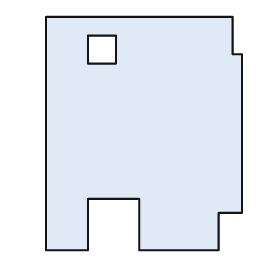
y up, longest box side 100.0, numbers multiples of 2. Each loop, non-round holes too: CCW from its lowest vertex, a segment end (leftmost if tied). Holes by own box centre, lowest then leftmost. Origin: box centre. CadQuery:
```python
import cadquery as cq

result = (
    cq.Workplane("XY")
    .moveTo(-42.0, -50.0)
    .lineTo(-24.0, -50.0)
    .lineTo(-24.0, -28.0)
    .lineTo(-2.0, -28.0)
    .lineTo(-2.0, -50.0)
    .lineTo(32.0, -50.0)
    .lineTo(32.0, -34.0)
    .lineTo(42.0, -34.0)
    .lineTo(42.0, 34.0)
    .lineTo(38.0, 34.0)
    .lineTo(38.0, 50.0)
    .lineTo(-42.0, 50.0)
    .close()
    .moveTo(-24.0, 30.0)
    .lineTo(-12.0, 30.0)
    .lineTo(-12.0, 42.0)
    .lineTo(-24.0, 42.0)
    .close()
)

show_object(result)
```